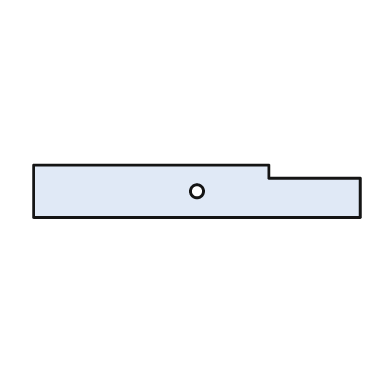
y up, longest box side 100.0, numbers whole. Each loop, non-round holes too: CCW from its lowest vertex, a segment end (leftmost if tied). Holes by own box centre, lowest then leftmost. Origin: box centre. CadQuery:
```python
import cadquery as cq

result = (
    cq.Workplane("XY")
    .moveTo(-50.0, -8.0)
    .lineTo(50.0, -8.0)
    .lineTo(50.0, 4.0)
    .lineTo(22.0, 4.0)
    .lineTo(22.0, 8.0)
    .lineTo(-50.0, 8.0)
    .close()
    .moveTo(0.0, 0.0)
    .circle(2.0)
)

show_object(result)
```